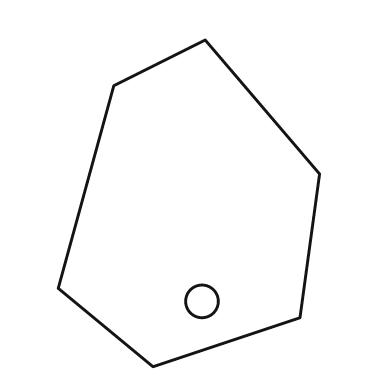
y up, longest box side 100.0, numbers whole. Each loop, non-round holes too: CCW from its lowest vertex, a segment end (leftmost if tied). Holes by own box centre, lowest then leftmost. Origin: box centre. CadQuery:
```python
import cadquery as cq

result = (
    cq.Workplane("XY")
    .moveTo(-11.0, -50.0)
    .lineTo(34.0, -35.0)
    .lineTo(40.0, 9.0)
    .lineTo(5.0, 50.0)
    .lineTo(-23.0, 36.0)
    .lineTo(-40.0, -26.0)
    .close()
    .moveTo(4.0, -30.0)
    .circle(5.0)
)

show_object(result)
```